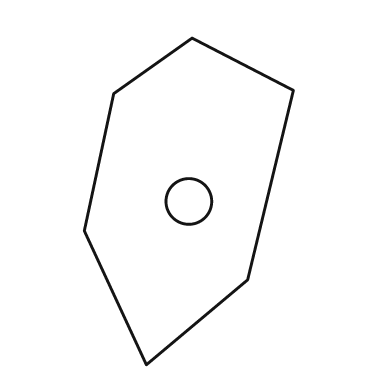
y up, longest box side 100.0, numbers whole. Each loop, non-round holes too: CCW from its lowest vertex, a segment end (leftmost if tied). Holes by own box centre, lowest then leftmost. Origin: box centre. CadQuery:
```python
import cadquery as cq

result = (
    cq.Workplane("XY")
    .moveTo(-13.0, -50.0)
    .lineTo(18.0, -24.0)
    .lineTo(32.0, 34.0)
    .lineTo(1.0, 50.0)
    .lineTo(-23.0, 33.0)
    .lineTo(-32.0, -9.0)
    .close()
    .moveTo(0.0, 0.0)
    .circle(7.0)
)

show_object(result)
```